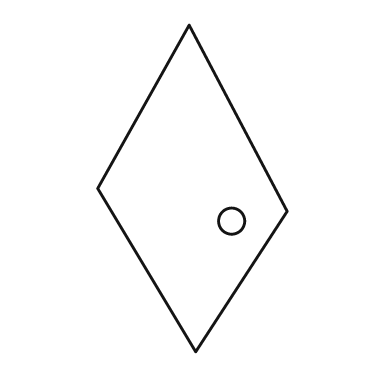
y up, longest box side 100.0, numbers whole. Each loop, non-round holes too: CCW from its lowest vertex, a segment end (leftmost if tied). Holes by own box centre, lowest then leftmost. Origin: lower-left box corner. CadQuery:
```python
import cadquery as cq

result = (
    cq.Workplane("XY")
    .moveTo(30.0, 0.0)
    .lineTo(58.0, 43.0)
    .lineTo(28.0, 100.0)
    .lineTo(0.0, 50.0)
    .close()
    .moveTo(41.0, 40.0)
    .circle(4.0)
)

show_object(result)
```